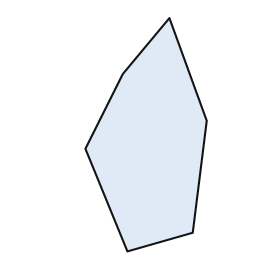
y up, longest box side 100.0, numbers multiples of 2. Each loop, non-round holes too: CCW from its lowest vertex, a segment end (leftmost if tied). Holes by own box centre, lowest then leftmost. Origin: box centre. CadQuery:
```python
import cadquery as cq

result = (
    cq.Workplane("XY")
    .moveTo(-8.0, -50.0)
    .lineTo(20.0, -42.0)
    .lineTo(26.0, 6.0)
    .lineTo(10.0, 50.0)
    .lineTo(-10.0, 26.0)
    .lineTo(-26.0, -6.0)
    .close()
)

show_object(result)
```